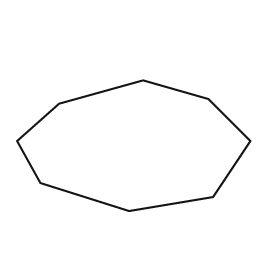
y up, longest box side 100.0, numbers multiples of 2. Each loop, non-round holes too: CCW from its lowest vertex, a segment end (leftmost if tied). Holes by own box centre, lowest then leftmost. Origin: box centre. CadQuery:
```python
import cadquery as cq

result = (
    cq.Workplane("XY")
    .moveTo(-2.0, -28.0)
    .lineTo(34.0, -22.0)
    .lineTo(50.0, 2.0)
    .lineTo(32.0, 20.0)
    .lineTo(4.0, 28.0)
    .lineTo(-32.0, 18.0)
    .lineTo(-50.0, 2.0)
    .lineTo(-40.0, -16.0)
    .close()
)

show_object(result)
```